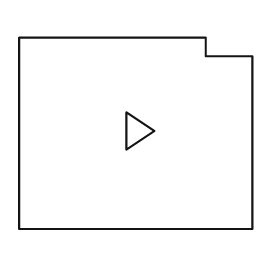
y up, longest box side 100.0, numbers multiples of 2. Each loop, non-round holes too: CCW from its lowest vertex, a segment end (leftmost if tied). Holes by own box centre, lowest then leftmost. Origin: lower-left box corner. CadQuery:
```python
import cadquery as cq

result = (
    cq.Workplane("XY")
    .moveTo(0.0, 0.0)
    .lineTo(100.0, 0.0)
    .lineTo(100.0, 74.0)
    .lineTo(80.0, 74.0)
    .lineTo(80.0, 82.0)
    .lineTo(0.0, 82.0)
    .close()
    .moveTo(46.0, 34.0)
    .lineTo(58.0, 42.0)
    .lineTo(46.0, 50.0)
    .close()
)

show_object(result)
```